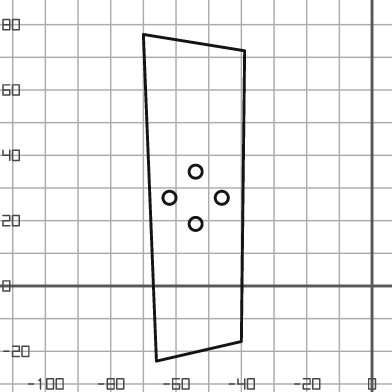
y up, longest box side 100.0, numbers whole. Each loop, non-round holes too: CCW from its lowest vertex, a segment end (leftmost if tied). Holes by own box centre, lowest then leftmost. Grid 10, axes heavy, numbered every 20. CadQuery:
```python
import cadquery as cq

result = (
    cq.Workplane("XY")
    .moveTo(-66.0, -23.0)
    .lineTo(-40.0, -17.0)
    .lineTo(-39.0, 72.0)
    .lineTo(-70.0, 77.0)
    .close()
    .moveTo(-54.0, 19.0)
    .circle(2.0)
    .moveTo(-62.0, 27.0)
    .circle(2.0)
    .moveTo(-46.0, 27.0)
    .circle(2.0)
    .moveTo(-54.0, 35.0)
    .circle(2.0)
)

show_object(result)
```